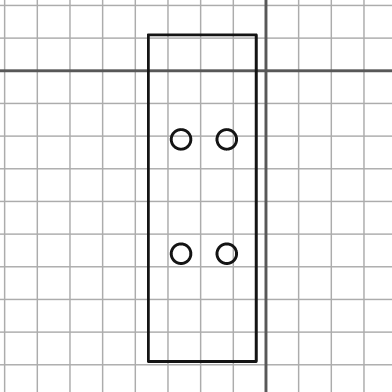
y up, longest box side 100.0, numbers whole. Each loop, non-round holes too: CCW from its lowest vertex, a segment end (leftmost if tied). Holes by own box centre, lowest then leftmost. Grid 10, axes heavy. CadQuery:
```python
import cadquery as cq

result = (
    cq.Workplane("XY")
    .moveTo(-36.0, -89.0)
    .lineTo(-3.0, -89.0)
    .lineTo(-3.0, 11.0)
    .lineTo(-36.0, 11.0)
    .close()
    .moveTo(-26.0, -56.0)
    .circle(3.0)
    .moveTo(-12.0, -56.0)
    .circle(3.0)
    .moveTo(-26.0, -21.0)
    .circle(3.0)
    .moveTo(-12.0, -21.0)
    .circle(3.0)
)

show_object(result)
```